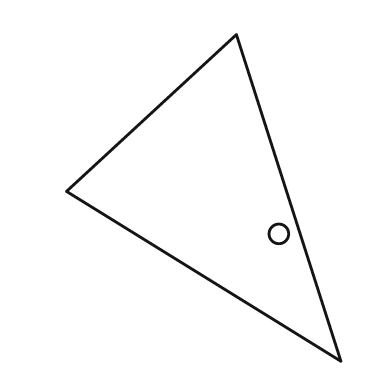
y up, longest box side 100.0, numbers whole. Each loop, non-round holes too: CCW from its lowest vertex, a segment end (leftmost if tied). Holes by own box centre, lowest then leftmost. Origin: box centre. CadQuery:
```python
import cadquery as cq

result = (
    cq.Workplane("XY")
    .moveTo(42.0, -50.0)
    .lineTo(10.0, 50.0)
    .lineTo(-42.0, 2.0)
    .close()
    .moveTo(23.0, -11.0)
    .circle(3.0)
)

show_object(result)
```